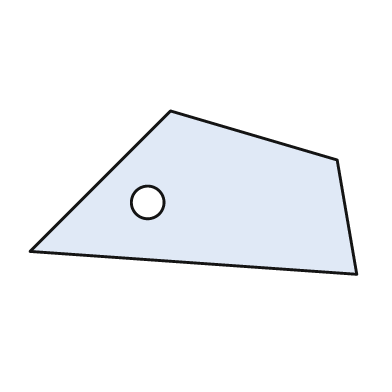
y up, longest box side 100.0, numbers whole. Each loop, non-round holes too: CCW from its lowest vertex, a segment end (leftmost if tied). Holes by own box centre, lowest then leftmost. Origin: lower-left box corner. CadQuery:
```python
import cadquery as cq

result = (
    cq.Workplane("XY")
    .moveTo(100.0, 0.0)
    .lineTo(94.0, 35.0)
    .lineTo(43.0, 50.0)
    .lineTo(0.0, 7.0)
    .close()
    .moveTo(36.0, 22.0)
    .circle(5.0)
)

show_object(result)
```